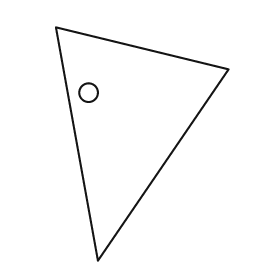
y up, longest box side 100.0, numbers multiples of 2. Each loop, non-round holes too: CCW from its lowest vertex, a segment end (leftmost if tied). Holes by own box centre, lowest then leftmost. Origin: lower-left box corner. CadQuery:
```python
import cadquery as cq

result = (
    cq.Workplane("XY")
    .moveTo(18.0, 0.0)
    .lineTo(74.0, 82.0)
    .lineTo(0.0, 100.0)
    .close()
    .moveTo(14.0, 72.0)
    .circle(4.0)
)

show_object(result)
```